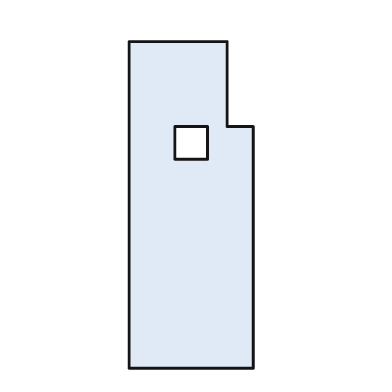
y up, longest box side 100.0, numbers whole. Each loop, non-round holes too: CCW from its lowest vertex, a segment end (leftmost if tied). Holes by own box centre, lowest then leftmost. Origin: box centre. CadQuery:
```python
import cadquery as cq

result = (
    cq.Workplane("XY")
    .moveTo(-19.0, -50.0)
    .lineTo(19.0, -50.0)
    .lineTo(19.0, 24.0)
    .lineTo(11.0, 24.0)
    .lineTo(11.0, 50.0)
    .lineTo(-19.0, 50.0)
    .close()
    .moveTo(-5.0, 14.0)
    .lineTo(5.0, 14.0)
    .lineTo(5.0, 24.0)
    .lineTo(-5.0, 24.0)
    .close()
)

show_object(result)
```